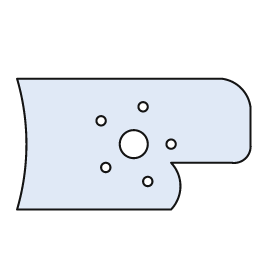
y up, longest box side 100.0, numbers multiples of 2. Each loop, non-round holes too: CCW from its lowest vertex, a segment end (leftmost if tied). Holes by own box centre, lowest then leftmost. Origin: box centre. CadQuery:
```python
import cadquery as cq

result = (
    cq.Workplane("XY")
    .moveTo(-50.0, -28.0)
    .lineTo(16.0, -28.0)
    .threePointArc((20.0, -18.0), (16.0, -8.0))
    .lineTo(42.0, -8.0)
    .threePointArc((48.0, -6.0), (50.0, 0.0))
    .lineTo(50.0, 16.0)
    .threePointArc((46.0, 24.0), (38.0, 28.0))
    .lineTo(-50.0, 28.0)
    .threePointArc((-46.0, 0.0), (-50.0, -28.0))
    .close()
    .moveTo(6.0, -16.0)
    .circle(2.0)
    .moveTo(-12.0, -10.0)
    .circle(2.0)
    .moveTo(0.0, 0.0)
    .circle(6.0)
    .moveTo(16.0, 0.0)
    .circle(2.0)
    .moveTo(-14.0, 10.0)
    .circle(2.0)
    .moveTo(4.0, 16.0)
    .circle(2.0)
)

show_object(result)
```